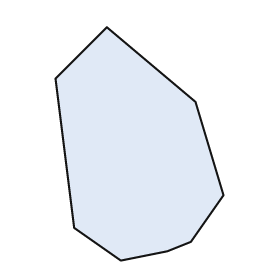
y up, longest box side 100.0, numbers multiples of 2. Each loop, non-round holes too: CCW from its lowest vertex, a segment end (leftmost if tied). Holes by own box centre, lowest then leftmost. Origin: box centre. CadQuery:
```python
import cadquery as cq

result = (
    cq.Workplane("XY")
    .moveTo(-8.0, -50.0)
    .lineTo(12.0, -46.0)
    .lineTo(22.0, -42.0)
    .lineTo(36.0, -22.0)
    .lineTo(24.0, 18.0)
    .lineTo(-14.0, 50.0)
    .lineTo(-36.0, 28.0)
    .lineTo(-28.0, -36.0)
    .close()
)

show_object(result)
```